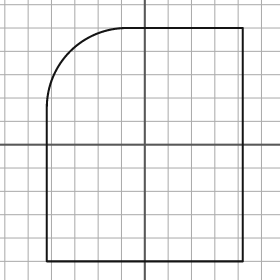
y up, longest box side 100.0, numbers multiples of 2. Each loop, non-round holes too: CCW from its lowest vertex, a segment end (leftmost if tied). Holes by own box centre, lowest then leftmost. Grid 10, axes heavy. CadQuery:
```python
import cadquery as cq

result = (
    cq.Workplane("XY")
    .moveTo(-42.0, -50.0)
    .lineTo(42.0, -50.0)
    .lineTo(42.0, 50.0)
    .lineTo(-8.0, 50.0)
    .threePointArc((-32.0, 40.0), (-42.0, 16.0))
    .close()
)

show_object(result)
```